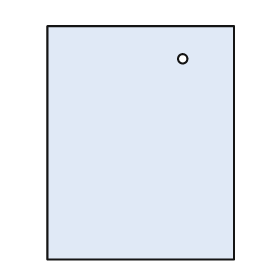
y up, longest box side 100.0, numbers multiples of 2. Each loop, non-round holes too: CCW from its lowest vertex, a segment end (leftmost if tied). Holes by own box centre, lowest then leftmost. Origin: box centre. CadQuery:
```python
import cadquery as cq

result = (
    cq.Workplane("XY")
    .moveTo(-40.0, -50.0)
    .lineTo(40.0, -50.0)
    .lineTo(40.0, 50.0)
    .lineTo(-40.0, 50.0)
    .close()
    .moveTo(18.0, 36.0)
    .circle(2.0)
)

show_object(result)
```